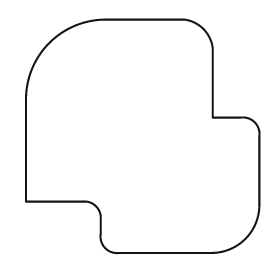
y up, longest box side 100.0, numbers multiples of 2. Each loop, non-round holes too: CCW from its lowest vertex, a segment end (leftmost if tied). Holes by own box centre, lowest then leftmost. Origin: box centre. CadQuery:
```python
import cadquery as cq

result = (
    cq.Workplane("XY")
    .moveTo(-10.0, -50.0)
    .lineTo(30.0, -50.0)
    .threePointArc((44.0, -44.0), (50.0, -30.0))
    .lineTo(50.0, 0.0)
    .threePointArc((48.0, 6.0), (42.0, 8.0))
    .lineTo(30.0, 8.0)
    .lineTo(30.0, 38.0)
    .threePointArc((26.0, 46.0), (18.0, 50.0))
    .lineTo(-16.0, 50.0)
    .threePointArc((-40.0, 40.0), (-50.0, 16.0))
    .lineTo(-50.0, -28.0)
    .lineTo(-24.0, -28.0)
    .threePointArc((-20.0, -30.0), (-18.0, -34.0))
    .lineTo(-18.0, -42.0)
    .threePointArc((-16.0, -48.0), (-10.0, -50.0))
    .close()
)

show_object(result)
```